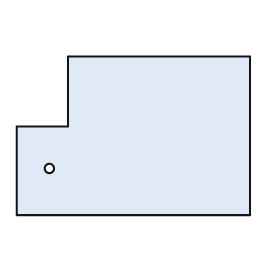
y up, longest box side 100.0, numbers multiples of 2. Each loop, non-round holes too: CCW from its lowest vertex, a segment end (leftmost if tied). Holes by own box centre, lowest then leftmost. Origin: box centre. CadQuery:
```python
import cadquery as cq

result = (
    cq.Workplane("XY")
    .moveTo(-50.0, -34.0)
    .lineTo(50.0, -34.0)
    .lineTo(50.0, 34.0)
    .lineTo(-28.0, 34.0)
    .lineTo(-28.0, 4.0)
    .lineTo(-50.0, 4.0)
    .close()
    .moveTo(-36.0, -14.0)
    .circle(2.0)
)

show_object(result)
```